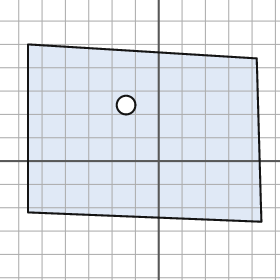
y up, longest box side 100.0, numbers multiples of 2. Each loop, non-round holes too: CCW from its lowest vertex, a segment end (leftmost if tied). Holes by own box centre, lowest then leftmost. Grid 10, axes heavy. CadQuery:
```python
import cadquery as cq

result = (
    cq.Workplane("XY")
    .moveTo(44.0, -26.0)
    .lineTo(42.0, 44.0)
    .lineTo(-56.0, 50.0)
    .lineTo(-56.0, -22.0)
    .close()
    .moveTo(-14.0, 24.0)
    .circle(4.0)
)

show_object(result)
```